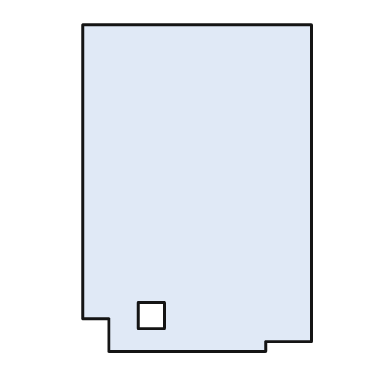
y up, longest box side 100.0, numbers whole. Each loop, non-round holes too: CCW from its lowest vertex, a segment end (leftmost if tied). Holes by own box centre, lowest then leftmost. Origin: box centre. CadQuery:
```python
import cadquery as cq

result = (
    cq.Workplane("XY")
    .moveTo(-27.0, -50.0)
    .lineTo(21.0, -50.0)
    .lineTo(21.0, -47.0)
    .lineTo(35.0, -47.0)
    .lineTo(35.0, 50.0)
    .lineTo(-35.0, 50.0)
    .lineTo(-35.0, -40.0)
    .lineTo(-27.0, -40.0)
    .close()
    .moveTo(-18.0, -43.0)
    .lineTo(-10.0, -43.0)
    .lineTo(-10.0, -35.0)
    .lineTo(-18.0, -35.0)
    .close()
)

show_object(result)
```